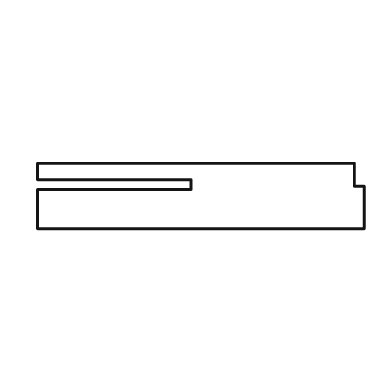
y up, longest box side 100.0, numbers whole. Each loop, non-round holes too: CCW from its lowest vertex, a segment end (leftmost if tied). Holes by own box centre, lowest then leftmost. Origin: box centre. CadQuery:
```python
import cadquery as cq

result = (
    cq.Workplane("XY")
    .moveTo(-50.0, -10.0)
    .lineTo(50.0, -10.0)
    .lineTo(50.0, 3.0)
    .lineTo(47.0, 3.0)
    .lineTo(47.0, 10.0)
    .lineTo(-50.0, 10.0)
    .lineTo(-50.0, 5.0)
    .lineTo(-3.0, 5.0)
    .lineTo(-3.0, 2.0)
    .lineTo(-50.0, 2.0)
    .close()
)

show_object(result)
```